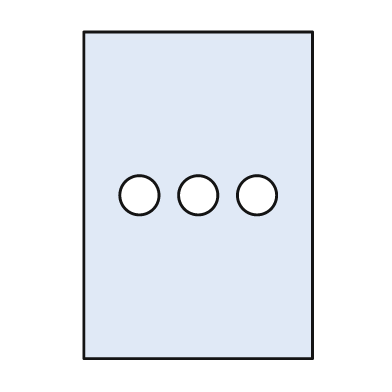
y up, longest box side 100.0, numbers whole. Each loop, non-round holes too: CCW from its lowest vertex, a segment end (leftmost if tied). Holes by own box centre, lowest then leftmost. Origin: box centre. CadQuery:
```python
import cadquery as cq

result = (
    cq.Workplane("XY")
    .moveTo(-35.0, -50.0)
    .lineTo(35.0, -50.0)
    .lineTo(35.0, 50.0)
    .lineTo(-35.0, 50.0)
    .close()
    .moveTo(-18.0, 0.0)
    .circle(6.0)
    .moveTo(0.0, 0.0)
    .circle(6.0)
    .moveTo(18.0, 0.0)
    .circle(6.0)
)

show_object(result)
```